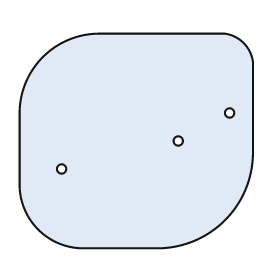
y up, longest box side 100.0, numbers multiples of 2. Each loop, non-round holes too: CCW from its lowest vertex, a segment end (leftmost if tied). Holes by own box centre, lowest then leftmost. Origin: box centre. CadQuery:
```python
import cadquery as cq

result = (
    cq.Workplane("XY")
    .moveTo(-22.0, -46.0)
    .lineTo(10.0, -46.0)
    .threePointArc((38.0, -34.0), (50.0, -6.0))
    .lineTo(50.0, 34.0)
    .threePointArc((46.0, 42.0), (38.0, 46.0))
    .lineTo(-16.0, 46.0)
    .threePointArc((-40.0, 36.0), (-50.0, 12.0))
    .lineTo(-50.0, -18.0)
    .threePointArc((-42.0, -38.0), (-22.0, -46.0))
    .close()
    .moveTo(-32.0, -12.0)
    .circle(2.0)
    .moveTo(18.0, 0.0)
    .circle(2.0)
    .moveTo(40.0, 12.0)
    .circle(2.0)
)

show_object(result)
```